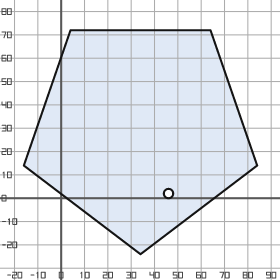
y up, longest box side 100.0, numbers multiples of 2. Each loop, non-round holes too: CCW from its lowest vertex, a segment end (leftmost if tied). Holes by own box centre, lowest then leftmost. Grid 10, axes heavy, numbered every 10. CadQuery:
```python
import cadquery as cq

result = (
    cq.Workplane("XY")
    .moveTo(34.0, -24.0)
    .lineTo(84.0, 14.0)
    .lineTo(64.0, 72.0)
    .lineTo(4.0, 72.0)
    .lineTo(-16.0, 14.0)
    .close()
    .moveTo(46.0, 2.0)
    .circle(2.0)
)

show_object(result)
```